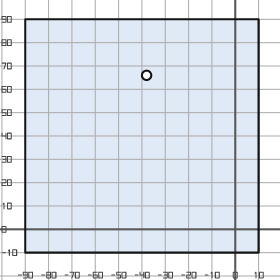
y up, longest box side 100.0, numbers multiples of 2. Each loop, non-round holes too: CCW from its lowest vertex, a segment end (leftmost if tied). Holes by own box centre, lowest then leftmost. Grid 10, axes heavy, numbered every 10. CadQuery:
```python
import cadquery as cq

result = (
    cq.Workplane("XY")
    .moveTo(-90.0, -10.0)
    .lineTo(10.0, -10.0)
    .lineTo(10.0, 90.0)
    .lineTo(-90.0, 90.0)
    .close()
    .moveTo(-38.0, 66.0)
    .circle(2.0)
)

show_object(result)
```